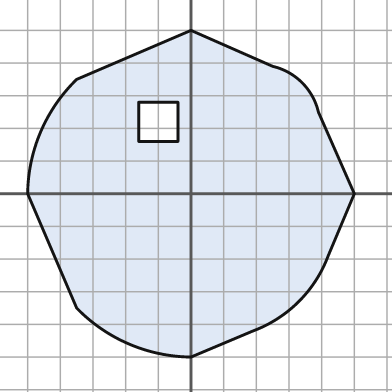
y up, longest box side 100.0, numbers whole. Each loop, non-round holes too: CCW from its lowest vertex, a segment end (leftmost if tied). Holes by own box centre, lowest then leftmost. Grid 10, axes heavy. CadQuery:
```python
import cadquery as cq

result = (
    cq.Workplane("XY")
    .moveTo(0.0, -50.0)
    .lineTo(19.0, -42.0)
    .threePointArc((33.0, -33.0), (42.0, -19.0))
    .lineTo(50.0, 0.0)
    .lineTo(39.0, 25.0)
    .threePointArc((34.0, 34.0), (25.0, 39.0))
    .lineTo(0.0, 50.0)
    .lineTo(-35.0, 35.0)
    .threePointArc((-46.0, 19.0), (-50.0, 0.0))
    .lineTo(-35.0, -35.0)
    .threePointArc((-19.0, -46.0), (0.0, -50.0))
    .close()
    .moveTo(-16.0, 16.0)
    .lineTo(-4.0, 16.0)
    .lineTo(-4.0, 28.0)
    .lineTo(-16.0, 28.0)
    .close()
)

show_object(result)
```